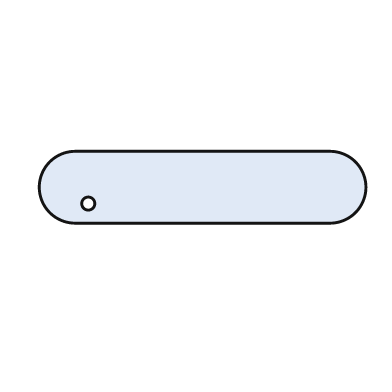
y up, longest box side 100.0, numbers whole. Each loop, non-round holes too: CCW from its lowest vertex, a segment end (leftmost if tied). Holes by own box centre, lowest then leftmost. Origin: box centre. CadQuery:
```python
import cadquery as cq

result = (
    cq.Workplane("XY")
    .moveTo(-39.0, -11.0)
    .lineTo(39.0, -11.0)
    .threePointArc((50.0, 0.0), (39.0, 11.0))
    .lineTo(-39.0, 11.0)
    .threePointArc((-50.0, 0.0), (-39.0, -11.0))
    .close()
    .moveTo(-35.0, -5.0)
    .circle(2.0)
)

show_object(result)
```